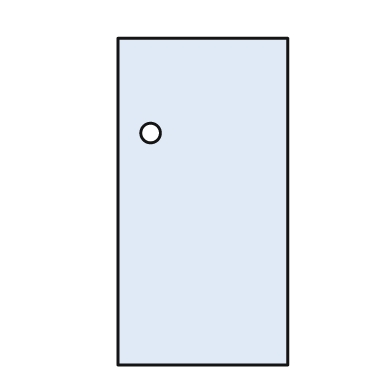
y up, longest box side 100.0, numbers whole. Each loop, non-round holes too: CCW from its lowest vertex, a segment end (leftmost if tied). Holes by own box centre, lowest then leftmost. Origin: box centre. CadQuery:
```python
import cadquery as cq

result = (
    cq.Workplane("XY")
    .moveTo(-26.0, -50.0)
    .lineTo(26.0, -50.0)
    .lineTo(26.0, 50.0)
    .lineTo(-26.0, 50.0)
    .close()
    .moveTo(-16.0, 21.0)
    .circle(3.0)
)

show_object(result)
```